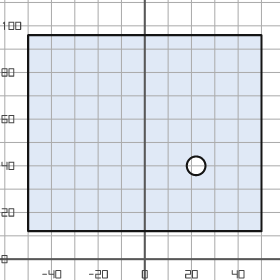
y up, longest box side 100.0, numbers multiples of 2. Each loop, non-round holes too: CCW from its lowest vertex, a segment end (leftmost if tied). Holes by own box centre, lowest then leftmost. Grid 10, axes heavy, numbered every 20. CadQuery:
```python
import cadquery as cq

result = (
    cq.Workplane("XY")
    .moveTo(-50.0, 12.0)
    .lineTo(50.0, 12.0)
    .lineTo(50.0, 96.0)
    .lineTo(-50.0, 96.0)
    .close()
    .moveTo(22.0, 40.0)
    .circle(4.0)
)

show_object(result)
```